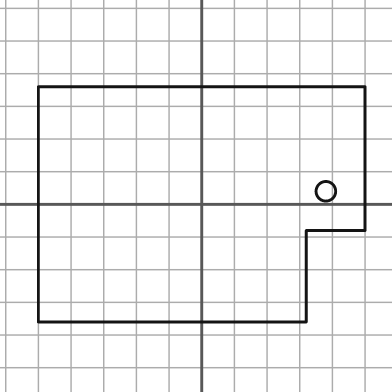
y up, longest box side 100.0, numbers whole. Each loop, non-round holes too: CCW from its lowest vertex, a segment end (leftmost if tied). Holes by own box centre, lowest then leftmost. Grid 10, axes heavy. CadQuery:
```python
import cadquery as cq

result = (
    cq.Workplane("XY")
    .moveTo(-50.0, -36.0)
    .lineTo(32.0, -36.0)
    .lineTo(32.0, -8.0)
    .lineTo(50.0, -8.0)
    .lineTo(50.0, 36.0)
    .lineTo(-50.0, 36.0)
    .close()
    .moveTo(38.0, 4.0)
    .circle(3.0)
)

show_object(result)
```